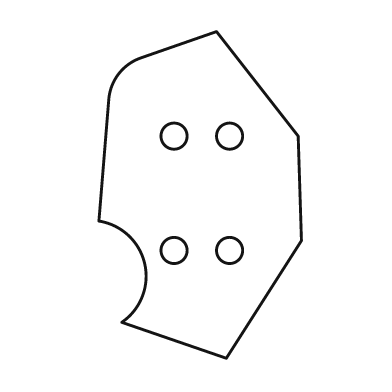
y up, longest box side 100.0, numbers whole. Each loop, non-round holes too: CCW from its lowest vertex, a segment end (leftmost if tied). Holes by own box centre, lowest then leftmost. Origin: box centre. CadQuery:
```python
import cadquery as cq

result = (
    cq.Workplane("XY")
    .moveTo(8.0, -50.0)
    .lineTo(31.0, -14.0)
    .lineTo(30.0, 18.0)
    .lineTo(5.0, 50.0)
    .lineTo(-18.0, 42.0)
    .threePointArc((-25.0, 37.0), (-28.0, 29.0))
    .lineTo(-31.0, -8.0)
    .threePointArc((-17.0, -21.0), (-24.0, -39.0))
    .close()
    .moveTo(-8.0, -17.0)
    .circle(4.0)
    .moveTo(9.0, -17.0)
    .circle(4.0)
    .moveTo(-8.0, 18.0)
    .circle(4.0)
    .moveTo(9.0, 18.0)
    .circle(4.0)
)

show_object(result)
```